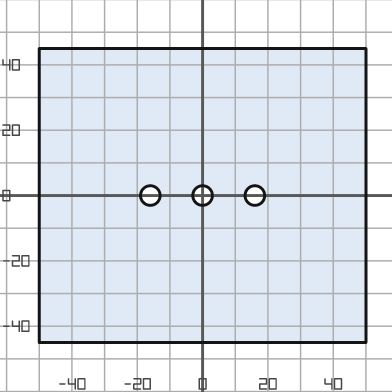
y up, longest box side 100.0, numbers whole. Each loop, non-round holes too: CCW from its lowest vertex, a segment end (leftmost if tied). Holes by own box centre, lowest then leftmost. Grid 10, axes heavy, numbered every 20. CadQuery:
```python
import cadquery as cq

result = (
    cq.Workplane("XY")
    .moveTo(-50.0, -45.0)
    .lineTo(50.0, -45.0)
    .lineTo(50.0, 45.0)
    .lineTo(-50.0, 45.0)
    .close()
    .moveTo(-16.0, 0.0)
    .circle(3.0)
    .moveTo(0.0, 0.0)
    .circle(3.0)
    .moveTo(16.0, 0.0)
    .circle(3.0)
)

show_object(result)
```